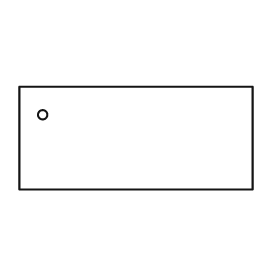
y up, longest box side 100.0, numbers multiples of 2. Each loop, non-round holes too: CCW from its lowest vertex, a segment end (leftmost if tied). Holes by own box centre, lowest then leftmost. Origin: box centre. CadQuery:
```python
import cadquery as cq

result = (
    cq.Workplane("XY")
    .moveTo(-50.0, -22.0)
    .lineTo(50.0, -22.0)
    .lineTo(50.0, 22.0)
    .lineTo(-50.0, 22.0)
    .close()
    .moveTo(-40.0, 10.0)
    .circle(2.0)
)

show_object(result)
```